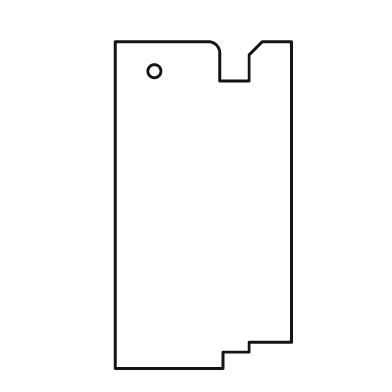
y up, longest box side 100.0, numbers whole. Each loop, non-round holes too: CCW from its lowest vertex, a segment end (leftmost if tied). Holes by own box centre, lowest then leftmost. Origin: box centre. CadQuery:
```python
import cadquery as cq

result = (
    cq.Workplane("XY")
    .moveTo(-27.0, -50.0)
    .lineTo(6.0, -50.0)
    .lineTo(6.0, -45.0)
    .lineTo(14.0, -45.0)
    .lineTo(14.0, -42.0)
    .lineTo(27.0, -42.0)
    .lineTo(27.0, 50.0)
    .lineTo(18.0, 50.0)
    .lineTo(14.0, 46.0)
    .lineTo(14.0, 38.0)
    .lineTo(5.0, 38.0)
    .lineTo(5.0, 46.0)
    .threePointArc((4.0, 49.0), (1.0, 50.0))
    .lineTo(-27.0, 50.0)
    .close()
    .moveTo(-15.0, 41.0)
    .circle(2.0)
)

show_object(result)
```